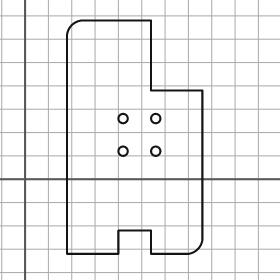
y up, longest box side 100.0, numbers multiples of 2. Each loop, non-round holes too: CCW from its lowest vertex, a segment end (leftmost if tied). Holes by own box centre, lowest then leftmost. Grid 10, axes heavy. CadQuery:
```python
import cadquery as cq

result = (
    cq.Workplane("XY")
    .moveTo(18.0, -32.0)
    .lineTo(40.0, -32.0)
    .lineTo(40.0, -22.0)
    .lineTo(54.0, -22.0)
    .lineTo(54.0, -32.0)
    .lineTo(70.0, -32.0)
    .threePointArc((74.0, -30.0), (76.0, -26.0))
    .lineTo(76.0, 38.0)
    .lineTo(54.0, 38.0)
    .lineTo(54.0, 68.0)
    .lineTo(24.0, 68.0)
    .threePointArc((20.0, 66.0), (18.0, 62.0))
    .close()
    .moveTo(42.0, 12.0)
    .circle(2.0)
    .moveTo(56.0, 12.0)
    .circle(2.0)
    .moveTo(42.0, 26.0)
    .circle(2.0)
    .moveTo(56.0, 26.0)
    .circle(2.0)
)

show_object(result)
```